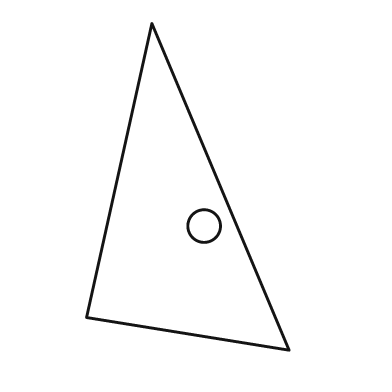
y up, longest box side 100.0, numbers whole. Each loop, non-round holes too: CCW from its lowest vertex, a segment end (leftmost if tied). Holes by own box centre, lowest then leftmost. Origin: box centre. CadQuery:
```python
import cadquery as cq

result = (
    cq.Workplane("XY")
    .moveTo(31.0, -50.0)
    .lineTo(-11.0, 50.0)
    .lineTo(-31.0, -40.0)
    .close()
    .moveTo(5.0, -12.0)
    .circle(5.0)
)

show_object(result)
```